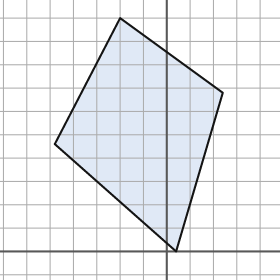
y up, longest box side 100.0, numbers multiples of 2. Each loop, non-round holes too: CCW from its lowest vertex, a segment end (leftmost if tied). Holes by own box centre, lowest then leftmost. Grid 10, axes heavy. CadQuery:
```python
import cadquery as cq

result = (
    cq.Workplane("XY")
    .moveTo(4.0, 0.0)
    .lineTo(24.0, 68.0)
    .lineTo(-20.0, 100.0)
    .lineTo(-48.0, 46.0)
    .close()
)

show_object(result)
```